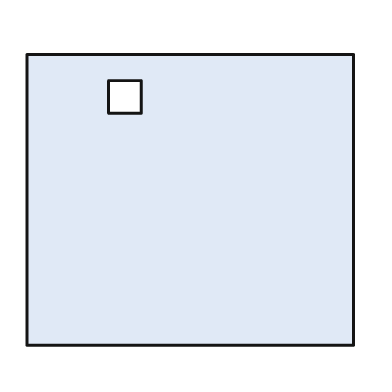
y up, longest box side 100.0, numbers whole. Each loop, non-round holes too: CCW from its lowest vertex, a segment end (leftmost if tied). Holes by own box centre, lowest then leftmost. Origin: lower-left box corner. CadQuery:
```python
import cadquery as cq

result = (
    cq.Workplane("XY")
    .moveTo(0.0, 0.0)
    .lineTo(100.0, 0.0)
    .lineTo(100.0, 89.0)
    .lineTo(0.0, 89.0)
    .close()
    .moveTo(25.0, 71.0)
    .lineTo(35.0, 71.0)
    .lineTo(35.0, 81.0)
    .lineTo(25.0, 81.0)
    .close()
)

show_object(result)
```